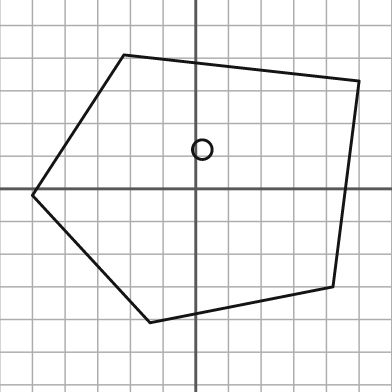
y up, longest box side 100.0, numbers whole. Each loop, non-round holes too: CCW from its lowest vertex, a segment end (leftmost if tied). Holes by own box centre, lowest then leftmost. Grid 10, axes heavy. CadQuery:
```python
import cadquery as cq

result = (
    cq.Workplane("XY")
    .moveTo(-14.0, -41.0)
    .lineTo(42.0, -30.0)
    .lineTo(50.0, 33.0)
    .lineTo(-22.0, 41.0)
    .lineTo(-50.0, -2.0)
    .close()
    .moveTo(2.0, 12.0)
    .circle(3.0)
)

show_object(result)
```